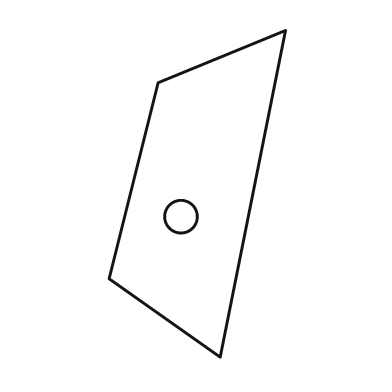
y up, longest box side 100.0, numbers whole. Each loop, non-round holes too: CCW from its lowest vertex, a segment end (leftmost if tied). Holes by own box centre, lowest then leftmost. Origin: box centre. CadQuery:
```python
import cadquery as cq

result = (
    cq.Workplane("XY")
    .moveTo(7.0, -50.0)
    .lineTo(27.0, 50.0)
    .lineTo(-12.0, 34.0)
    .lineTo(-27.0, -26.0)
    .close()
    .moveTo(-5.0, -7.0)
    .circle(5.0)
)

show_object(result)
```